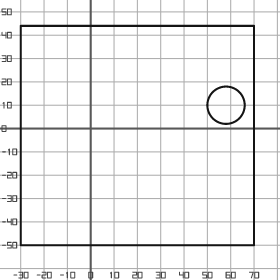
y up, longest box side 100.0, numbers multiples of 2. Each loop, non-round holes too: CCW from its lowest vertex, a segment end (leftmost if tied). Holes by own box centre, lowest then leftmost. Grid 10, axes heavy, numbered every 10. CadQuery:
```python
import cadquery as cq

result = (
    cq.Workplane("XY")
    .moveTo(-30.0, -50.0)
    .lineTo(70.0, -50.0)
    .lineTo(70.0, 44.0)
    .lineTo(-30.0, 44.0)
    .close()
    .moveTo(58.0, 10.0)
    .circle(8.0)
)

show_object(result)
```